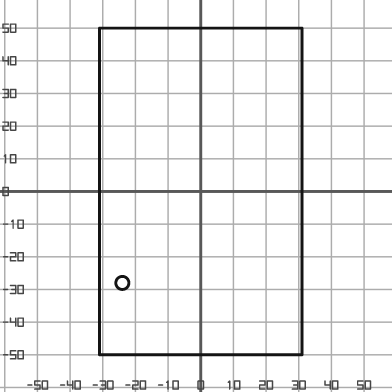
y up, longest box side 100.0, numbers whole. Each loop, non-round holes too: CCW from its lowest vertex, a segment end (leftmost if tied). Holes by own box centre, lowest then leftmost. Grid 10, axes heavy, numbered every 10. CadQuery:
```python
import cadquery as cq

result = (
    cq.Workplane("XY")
    .moveTo(-31.0, -50.0)
    .lineTo(31.0, -50.0)
    .lineTo(31.0, 50.0)
    .lineTo(-31.0, 50.0)
    .close()
    .moveTo(-24.0, -28.0)
    .circle(2.0)
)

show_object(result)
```